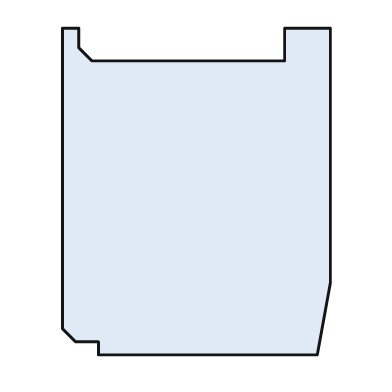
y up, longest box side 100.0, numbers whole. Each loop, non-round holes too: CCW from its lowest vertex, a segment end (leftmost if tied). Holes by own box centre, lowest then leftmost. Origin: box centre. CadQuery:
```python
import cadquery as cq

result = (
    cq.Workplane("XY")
    .moveTo(-30.0, -50.0)
    .lineTo(37.0, -50.0)
    .lineTo(41.0, -28.0)
    .lineTo(41.0, 50.0)
    .lineTo(27.0, 50.0)
    .lineTo(27.0, 40.0)
    .lineTo(-32.0, 40.0)
    .lineTo(-36.0, 44.0)
    .lineTo(-36.0, 50.0)
    .lineTo(-41.0, 50.0)
    .lineTo(-41.0, -42.0)
    .lineTo(-37.0, -46.0)
    .lineTo(-30.0, -46.0)
    .close()
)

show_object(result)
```